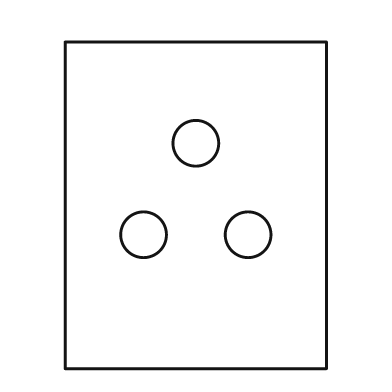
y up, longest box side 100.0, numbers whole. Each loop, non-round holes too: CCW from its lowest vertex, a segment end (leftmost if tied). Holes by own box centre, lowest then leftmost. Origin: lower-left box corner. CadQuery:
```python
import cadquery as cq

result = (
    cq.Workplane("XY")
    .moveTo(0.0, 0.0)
    .lineTo(80.0, 0.0)
    .lineTo(80.0, 100.0)
    .lineTo(0.0, 100.0)
    .close()
    .moveTo(24.0, 41.0)
    .circle(7.0)
    .moveTo(56.0, 41.0)
    .circle(7.0)
    .moveTo(40.0, 69.0)
    .circle(7.0)
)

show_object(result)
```